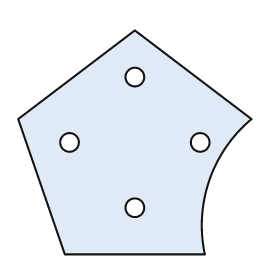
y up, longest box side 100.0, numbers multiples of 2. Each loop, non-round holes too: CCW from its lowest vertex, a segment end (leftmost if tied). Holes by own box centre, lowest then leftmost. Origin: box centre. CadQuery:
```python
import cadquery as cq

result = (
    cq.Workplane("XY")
    .moveTo(-30.0, -48.0)
    .lineTo(30.0, -48.0)
    .threePointArc((32.0, -16.0), (50.0, 10.0))
    .lineTo(0.0, 48.0)
    .lineTo(-50.0, 10.0)
    .close()
    .moveTo(0.0, -28.0)
    .circle(4.0)
    .moveTo(-28.0, 0.0)
    .circle(4.0)
    .moveTo(28.0, 0.0)
    .circle(4.0)
    .moveTo(0.0, 28.0)
    .circle(4.0)
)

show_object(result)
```